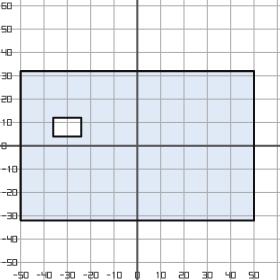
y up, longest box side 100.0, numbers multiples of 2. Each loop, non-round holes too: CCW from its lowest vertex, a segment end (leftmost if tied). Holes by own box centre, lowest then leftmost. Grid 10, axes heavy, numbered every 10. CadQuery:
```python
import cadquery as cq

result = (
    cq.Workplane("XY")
    .moveTo(-50.0, -32.0)
    .lineTo(50.0, -32.0)
    .lineTo(50.0, 32.0)
    .lineTo(-50.0, 32.0)
    .close()
    .moveTo(-36.0, 4.0)
    .lineTo(-24.0, 4.0)
    .lineTo(-24.0, 12.0)
    .lineTo(-36.0, 12.0)
    .close()
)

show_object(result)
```